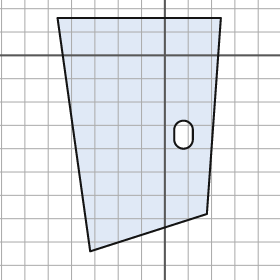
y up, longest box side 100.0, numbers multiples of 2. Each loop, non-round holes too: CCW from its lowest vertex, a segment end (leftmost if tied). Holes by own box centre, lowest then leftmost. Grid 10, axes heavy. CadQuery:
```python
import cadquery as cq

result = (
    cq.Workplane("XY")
    .moveTo(-32.0, -84.0)
    .lineTo(18.0, -68.0)
    .lineTo(24.0, 16.0)
    .lineTo(-46.0, 16.0)
    .close()
    .moveTo(4.0, -36.0)
    .threePointArc((8.0, -40.0), (12.0, -36.0))
    .lineTo(12.0, -32.0)
    .threePointArc((8.0, -28.0), (4.0, -32.0))
    .close()
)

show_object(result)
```